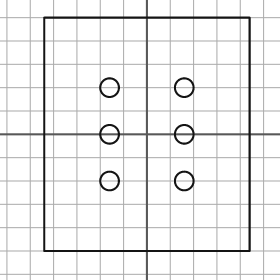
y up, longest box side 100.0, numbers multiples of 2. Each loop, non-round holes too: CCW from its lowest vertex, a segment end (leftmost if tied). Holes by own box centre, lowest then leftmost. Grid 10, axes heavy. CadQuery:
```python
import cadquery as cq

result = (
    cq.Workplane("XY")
    .moveTo(-44.0, -50.0)
    .lineTo(44.0, -50.0)
    .lineTo(44.0, 50.0)
    .lineTo(-44.0, 50.0)
    .close()
    .moveTo(-16.0, -20.0)
    .circle(4.0)
    .moveTo(16.0, -20.0)
    .circle(4.0)
    .moveTo(-16.0, 0.0)
    .circle(4.0)
    .moveTo(16.0, 0.0)
    .circle(4.0)
    .moveTo(-16.0, 20.0)
    .circle(4.0)
    .moveTo(16.0, 20.0)
    .circle(4.0)
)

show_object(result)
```